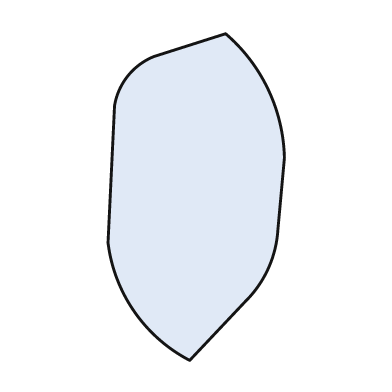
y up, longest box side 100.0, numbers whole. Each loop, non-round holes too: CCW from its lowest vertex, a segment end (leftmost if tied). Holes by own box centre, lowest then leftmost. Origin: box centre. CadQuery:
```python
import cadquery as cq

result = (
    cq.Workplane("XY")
    .moveTo(-2.0, -50.0)
    .lineTo(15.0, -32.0)
    .threePointArc((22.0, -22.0), (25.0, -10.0))
    .lineTo(27.0, 12.0)
    .threePointArc((22.0, 33.0), (9.0, 50.0))
    .lineTo(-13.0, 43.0)
    .threePointArc((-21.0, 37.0), (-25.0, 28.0))
    .lineTo(-27.0, -14.0)
    .threePointArc((-19.0, -35.0), (-2.0, -50.0))
    .close()
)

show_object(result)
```